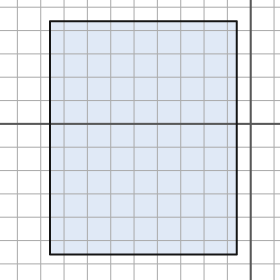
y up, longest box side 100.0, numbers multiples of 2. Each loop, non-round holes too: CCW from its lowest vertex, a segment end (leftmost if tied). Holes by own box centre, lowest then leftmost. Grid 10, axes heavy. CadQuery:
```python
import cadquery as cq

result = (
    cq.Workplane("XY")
    .moveTo(-86.0, -56.0)
    .lineTo(-6.0, -56.0)
    .lineTo(-6.0, 44.0)
    .lineTo(-86.0, 44.0)
    .close()
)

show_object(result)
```